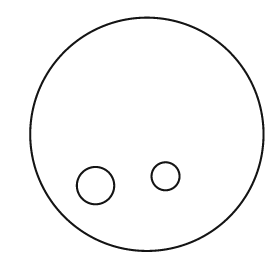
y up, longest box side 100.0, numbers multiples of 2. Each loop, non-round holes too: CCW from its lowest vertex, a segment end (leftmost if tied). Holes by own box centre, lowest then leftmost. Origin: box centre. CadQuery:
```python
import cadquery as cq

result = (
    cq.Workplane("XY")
    .moveTo(0.0, 0.0)
    .circle(50.0)
    .moveTo(-22.0, -22.0)
    .circle(8.0)
    .moveTo(8.0, -18.0)
    .circle(6.0)
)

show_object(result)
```